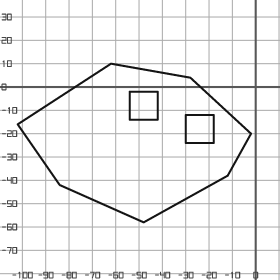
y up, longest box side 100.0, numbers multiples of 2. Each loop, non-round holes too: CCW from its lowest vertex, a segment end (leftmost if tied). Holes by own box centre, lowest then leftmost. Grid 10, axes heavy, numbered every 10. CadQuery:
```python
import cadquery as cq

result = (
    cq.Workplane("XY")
    .moveTo(-48.0, -58.0)
    .lineTo(-12.0, -38.0)
    .lineTo(-2.0, -20.0)
    .lineTo(-28.0, 4.0)
    .lineTo(-62.0, 10.0)
    .lineTo(-102.0, -16.0)
    .lineTo(-84.0, -42.0)
    .close()
    .moveTo(-30.0, -24.0)
    .lineTo(-18.0, -24.0)
    .lineTo(-18.0, -12.0)
    .lineTo(-30.0, -12.0)
    .close()
    .moveTo(-54.0, -14.0)
    .lineTo(-42.0, -14.0)
    .lineTo(-42.0, -2.0)
    .lineTo(-54.0, -2.0)
    .close()
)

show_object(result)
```